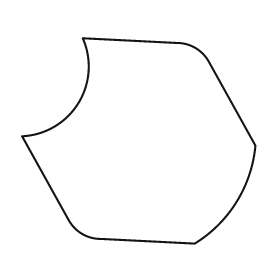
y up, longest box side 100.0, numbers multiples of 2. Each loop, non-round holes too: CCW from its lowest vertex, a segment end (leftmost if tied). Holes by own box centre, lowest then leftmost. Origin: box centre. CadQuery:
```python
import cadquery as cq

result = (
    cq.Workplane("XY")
    .moveTo(24.0, -44.0)
    .threePointArc((42.0, -26.0), (50.0, -2.0))
    .lineTo(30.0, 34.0)
    .threePointArc((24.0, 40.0), (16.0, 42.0))
    .lineTo(-24.0, 44.0)
    .threePointArc((-26.0, 16.0), (-50.0, 2.0))
    .lineTo(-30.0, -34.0)
    .threePointArc((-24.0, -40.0), (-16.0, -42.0))
    .close()
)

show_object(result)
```